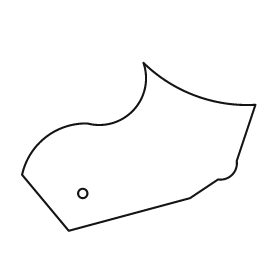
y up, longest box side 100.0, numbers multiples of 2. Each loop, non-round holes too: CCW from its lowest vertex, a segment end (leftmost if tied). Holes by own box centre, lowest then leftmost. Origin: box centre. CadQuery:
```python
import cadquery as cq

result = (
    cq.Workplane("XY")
    .moveTo(-30.0, -36.0)
    .lineTo(22.0, -22.0)
    .lineTo(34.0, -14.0)
    .threePointArc((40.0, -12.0), (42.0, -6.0))
    .lineTo(50.0, 18.0)
    .threePointArc((24.0, 22.0), (2.0, 36.0))
    .threePointArc((-2.0, 16.0), (-22.0, 10.0))
    .threePointArc((-40.0, 4.0), (-50.0, -12.0))
    .close()
    .moveTo(-24.0, -20.0)
    .circle(2.0)
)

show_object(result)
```